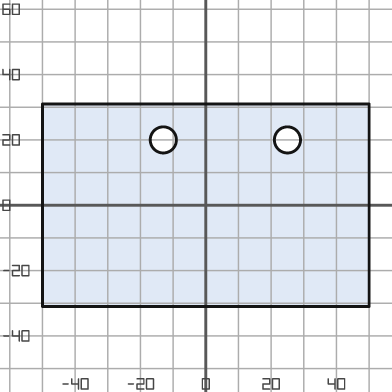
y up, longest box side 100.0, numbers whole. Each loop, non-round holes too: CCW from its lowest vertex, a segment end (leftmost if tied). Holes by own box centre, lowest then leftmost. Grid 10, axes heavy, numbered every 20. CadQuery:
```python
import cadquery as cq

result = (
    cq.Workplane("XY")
    .moveTo(-50.0, -31.0)
    .lineTo(50.0, -31.0)
    .lineTo(50.0, 31.0)
    .lineTo(-50.0, 31.0)
    .close()
    .moveTo(-13.0, 20.0)
    .circle(4.0)
    .moveTo(25.0, 20.0)
    .circle(4.0)
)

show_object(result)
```